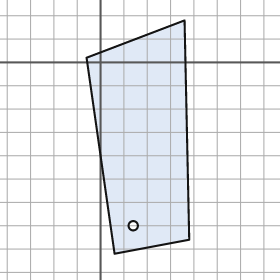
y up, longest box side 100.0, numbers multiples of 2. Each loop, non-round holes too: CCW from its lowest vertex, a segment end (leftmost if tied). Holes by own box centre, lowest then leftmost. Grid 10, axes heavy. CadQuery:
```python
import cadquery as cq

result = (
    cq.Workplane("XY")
    .moveTo(6.0, -82.0)
    .lineTo(38.0, -76.0)
    .lineTo(36.0, 18.0)
    .lineTo(-6.0, 2.0)
    .close()
    .moveTo(14.0, -70.0)
    .circle(2.0)
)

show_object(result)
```